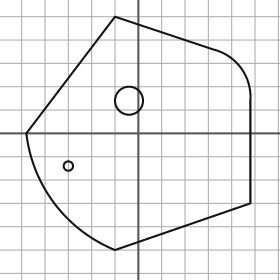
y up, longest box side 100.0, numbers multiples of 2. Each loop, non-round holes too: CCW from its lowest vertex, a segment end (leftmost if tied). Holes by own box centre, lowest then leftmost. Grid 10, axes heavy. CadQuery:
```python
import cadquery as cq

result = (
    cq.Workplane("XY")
    .moveTo(-10.0, -50.0)
    .lineTo(48.0, -30.0)
    .lineTo(48.0, 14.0)
    .threePointArc((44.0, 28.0), (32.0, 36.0))
    .lineTo(-10.0, 50.0)
    .lineTo(-48.0, 0.0)
    .threePointArc((-36.0, -30.0), (-10.0, -50.0))
    .close()
    .moveTo(-30.0, -14.0)
    .circle(2.0)
    .moveTo(-4.0, 14.0)
    .circle(6.0)
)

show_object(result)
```